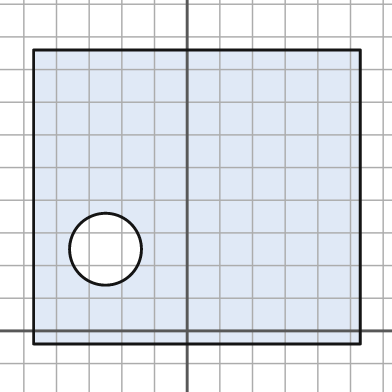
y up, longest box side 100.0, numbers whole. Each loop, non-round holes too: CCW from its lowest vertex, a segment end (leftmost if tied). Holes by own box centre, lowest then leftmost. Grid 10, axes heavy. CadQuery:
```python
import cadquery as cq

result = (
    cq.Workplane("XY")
    .moveTo(-47.0, -4.0)
    .lineTo(53.0, -4.0)
    .lineTo(53.0, 86.0)
    .lineTo(-47.0, 86.0)
    .close()
    .moveTo(-25.0, 25.0)
    .circle(11.0)
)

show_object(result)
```